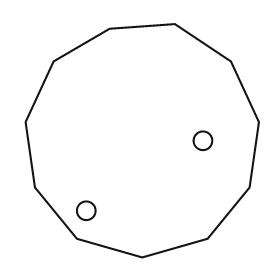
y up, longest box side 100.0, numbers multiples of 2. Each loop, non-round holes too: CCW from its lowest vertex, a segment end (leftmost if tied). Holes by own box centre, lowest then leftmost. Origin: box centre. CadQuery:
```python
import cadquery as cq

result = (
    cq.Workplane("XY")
    .moveTo(0.0, -50.0)
    .lineTo(28.0, -42.0)
    .lineTo(46.0, -20.0)
    .lineTo(50.0, 8.0)
    .lineTo(38.0, 34.0)
    .lineTo(14.0, 50.0)
    .lineTo(-14.0, 48.0)
    .lineTo(-38.0, 34.0)
    .lineTo(-50.0, 8.0)
    .lineTo(-46.0, -20.0)
    .lineTo(-28.0, -42.0)
    .close()
    .moveTo(-24.0, -30.0)
    .circle(4.0)
    .moveTo(26.0, 0.0)
    .circle(4.0)
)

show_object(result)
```